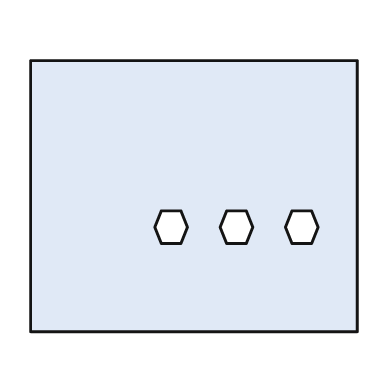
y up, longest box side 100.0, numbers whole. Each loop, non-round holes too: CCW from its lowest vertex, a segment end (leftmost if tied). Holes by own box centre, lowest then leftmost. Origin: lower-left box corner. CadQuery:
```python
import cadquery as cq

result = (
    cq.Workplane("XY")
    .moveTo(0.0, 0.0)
    .lineTo(100.0, 0.0)
    .lineTo(100.0, 83.0)
    .lineTo(0.0, 83.0)
    .close()
    .moveTo(40.0, 27.0)
    .lineTo(46.0, 27.0)
    .lineTo(48.0, 32.0)
    .lineTo(46.0, 37.0)
    .lineTo(40.0, 37.0)
    .lineTo(38.0, 32.0)
    .close()
    .moveTo(60.0, 27.0)
    .lineTo(66.0, 27.0)
    .lineTo(68.0, 32.0)
    .lineTo(66.0, 37.0)
    .lineTo(60.0, 37.0)
    .lineTo(58.0, 32.0)
    .close()
    .moveTo(80.0, 27.0)
    .lineTo(86.0, 27.0)
    .lineTo(88.0, 32.0)
    .lineTo(86.0, 37.0)
    .lineTo(80.0, 37.0)
    .lineTo(78.0, 32.0)
    .close()
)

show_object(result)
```